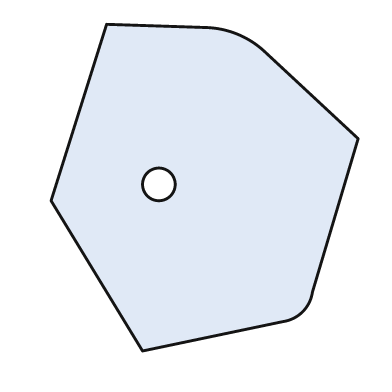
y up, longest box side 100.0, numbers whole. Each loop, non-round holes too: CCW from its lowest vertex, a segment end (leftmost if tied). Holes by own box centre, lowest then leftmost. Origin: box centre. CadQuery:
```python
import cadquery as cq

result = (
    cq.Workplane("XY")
    .moveTo(-19.0, -50.0)
    .lineTo(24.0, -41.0)
    .threePointArc((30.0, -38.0), (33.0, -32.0))
    .lineTo(47.0, 15.0)
    .lineTo(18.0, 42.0)
    .threePointArc((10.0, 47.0), (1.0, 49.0))
    .lineTo(-30.0, 50.0)
    .lineTo(-47.0, -4.0)
    .close()
    .moveTo(-14.0, 1.0)
    .circle(5.0)
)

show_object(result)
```